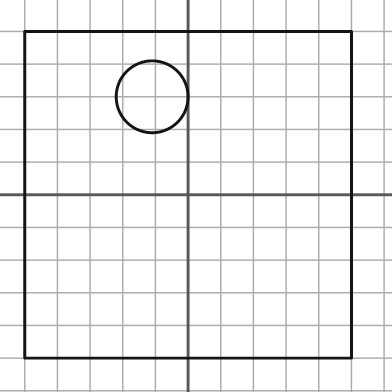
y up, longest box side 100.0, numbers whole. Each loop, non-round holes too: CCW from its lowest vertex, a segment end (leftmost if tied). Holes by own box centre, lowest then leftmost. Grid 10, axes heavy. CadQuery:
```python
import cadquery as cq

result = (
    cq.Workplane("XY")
    .moveTo(-50.0, -50.0)
    .lineTo(50.0, -50.0)
    .lineTo(50.0, 50.0)
    .lineTo(-50.0, 50.0)
    .close()
    .moveTo(-11.0, 30.0)
    .circle(11.0)
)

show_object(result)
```